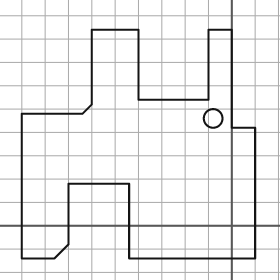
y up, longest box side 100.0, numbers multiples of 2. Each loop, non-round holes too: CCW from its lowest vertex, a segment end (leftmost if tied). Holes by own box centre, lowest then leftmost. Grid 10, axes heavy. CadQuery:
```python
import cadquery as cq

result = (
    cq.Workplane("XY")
    .moveTo(-90.0, -14.0)
    .lineTo(-76.0, -14.0)
    .lineTo(-70.0, -8.0)
    .lineTo(-70.0, 18.0)
    .lineTo(-44.0, 18.0)
    .lineTo(-44.0, -14.0)
    .lineTo(10.0, -14.0)
    .lineTo(10.0, 42.0)
    .lineTo(0.0, 42.0)
    .lineTo(0.0, 84.0)
    .lineTo(-10.0, 84.0)
    .lineTo(-10.0, 54.0)
    .lineTo(-40.0, 54.0)
    .lineTo(-40.0, 84.0)
    .lineTo(-60.0, 84.0)
    .lineTo(-60.0, 52.0)
    .lineTo(-64.0, 48.0)
    .lineTo(-90.0, 48.0)
    .close()
    .moveTo(-8.0, 46.0)
    .circle(4.0)
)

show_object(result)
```